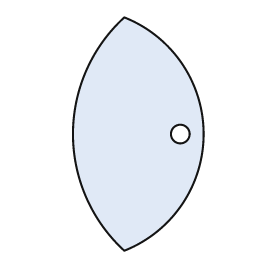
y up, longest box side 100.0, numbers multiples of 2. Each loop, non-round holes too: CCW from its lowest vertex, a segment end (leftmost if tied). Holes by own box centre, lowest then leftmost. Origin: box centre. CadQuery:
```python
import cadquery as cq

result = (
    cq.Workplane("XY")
    .moveTo(-6.0, -50.0)
    .threePointArc((28.0, 0.0), (-6.0, 50.0))
    .threePointArc((-28.0, 0.0), (-6.0, -50.0))
    .close()
    .moveTo(18.0, 0.0)
    .circle(4.0)
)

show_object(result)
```